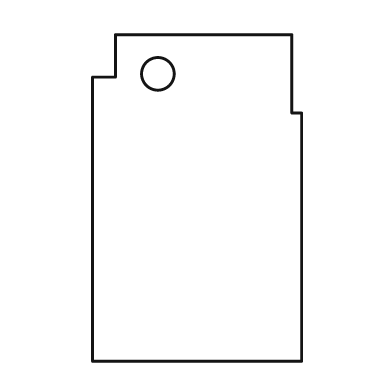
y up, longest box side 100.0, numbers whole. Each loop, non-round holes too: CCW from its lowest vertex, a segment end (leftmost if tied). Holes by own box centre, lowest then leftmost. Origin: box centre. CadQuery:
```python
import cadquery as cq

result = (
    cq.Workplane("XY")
    .moveTo(-32.0, -50.0)
    .lineTo(32.0, -50.0)
    .lineTo(32.0, 26.0)
    .lineTo(29.0, 26.0)
    .lineTo(29.0, 50.0)
    .lineTo(-25.0, 50.0)
    .lineTo(-25.0, 37.0)
    .lineTo(-32.0, 37.0)
    .close()
    .moveTo(-12.0, 38.0)
    .circle(5.0)
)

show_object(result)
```